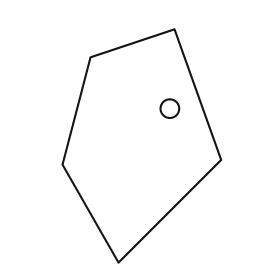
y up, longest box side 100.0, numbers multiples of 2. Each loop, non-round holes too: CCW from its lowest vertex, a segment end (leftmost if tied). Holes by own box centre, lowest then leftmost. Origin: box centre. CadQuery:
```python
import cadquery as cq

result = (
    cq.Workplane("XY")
    .moveTo(-10.0, -50.0)
    .lineTo(34.0, -6.0)
    .lineTo(14.0, 50.0)
    .lineTo(-22.0, 38.0)
    .lineTo(-34.0, -8.0)
    .close()
    .moveTo(12.0, 16.0)
    .circle(4.0)
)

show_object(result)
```